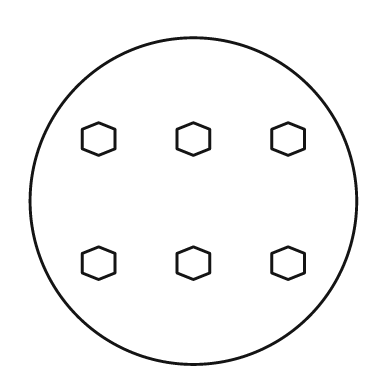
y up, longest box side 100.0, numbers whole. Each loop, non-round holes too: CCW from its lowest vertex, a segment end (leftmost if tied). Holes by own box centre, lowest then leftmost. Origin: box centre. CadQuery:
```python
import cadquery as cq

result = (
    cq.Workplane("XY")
    .moveTo(0.0, 0.0)
    .circle(50.0)
    .moveTo(-29.0, -24.0)
    .lineTo(-24.0, -22.0)
    .lineTo(-24.0, -16.0)
    .lineTo(-29.0, -14.0)
    .lineTo(-34.0, -16.0)
    .lineTo(-34.0, -22.0)
    .close()
    .moveTo(0.0, -24.0)
    .lineTo(5.0, -22.0)
    .lineTo(5.0, -16.0)
    .lineTo(0.0, -14.0)
    .lineTo(-5.0, -16.0)
    .lineTo(-5.0, -22.0)
    .close()
    .moveTo(29.0, -24.0)
    .lineTo(34.0, -22.0)
    .lineTo(34.0, -16.0)
    .lineTo(29.0, -14.0)
    .lineTo(24.0, -16.0)
    .lineTo(24.0, -22.0)
    .close()
    .moveTo(-29.0, 14.0)
    .lineTo(-24.0, 16.0)
    .lineTo(-24.0, 22.0)
    .lineTo(-29.0, 24.0)
    .lineTo(-34.0, 22.0)
    .lineTo(-34.0, 16.0)
    .close()
    .moveTo(0.0, 14.0)
    .lineTo(5.0, 16.0)
    .lineTo(5.0, 22.0)
    .lineTo(0.0, 24.0)
    .lineTo(-5.0, 22.0)
    .lineTo(-5.0, 16.0)
    .close()
    .moveTo(29.0, 14.0)
    .lineTo(34.0, 16.0)
    .lineTo(34.0, 22.0)
    .lineTo(29.0, 24.0)
    .lineTo(24.0, 22.0)
    .lineTo(24.0, 16.0)
    .close()
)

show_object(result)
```